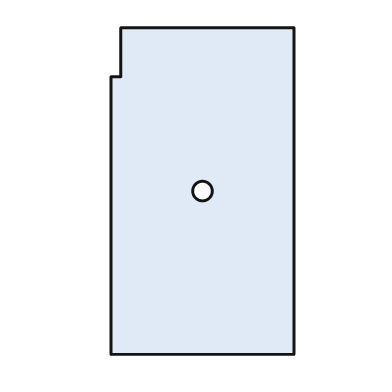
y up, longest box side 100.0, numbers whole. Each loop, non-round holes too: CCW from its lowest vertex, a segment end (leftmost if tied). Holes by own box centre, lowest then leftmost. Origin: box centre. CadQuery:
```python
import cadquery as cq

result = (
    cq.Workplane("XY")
    .moveTo(-28.0, -50.0)
    .lineTo(28.0, -50.0)
    .lineTo(28.0, 50.0)
    .lineTo(-25.0, 50.0)
    .lineTo(-25.0, 35.0)
    .lineTo(-28.0, 35.0)
    .close()
    .moveTo(0.0, 0.0)
    .circle(3.0)
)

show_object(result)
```